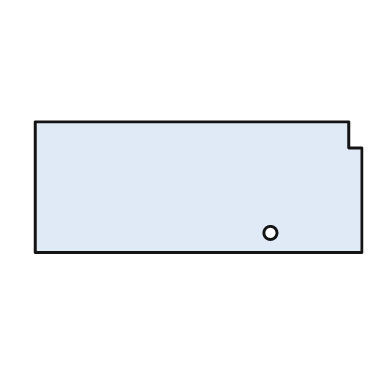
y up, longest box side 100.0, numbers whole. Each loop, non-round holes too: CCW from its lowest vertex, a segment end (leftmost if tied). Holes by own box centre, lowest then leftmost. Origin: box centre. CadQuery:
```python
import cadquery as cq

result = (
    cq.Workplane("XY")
    .moveTo(-50.0, -20.0)
    .lineTo(50.0, -20.0)
    .lineTo(50.0, 12.0)
    .lineTo(46.0, 12.0)
    .lineTo(46.0, 20.0)
    .lineTo(-50.0, 20.0)
    .close()
    .moveTo(22.0, -14.0)
    .circle(2.0)
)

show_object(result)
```